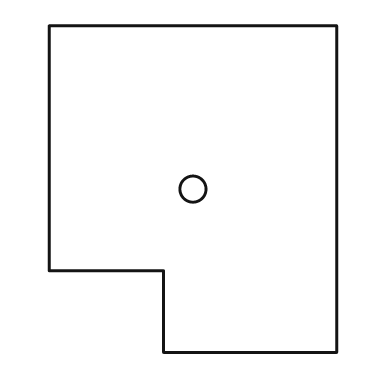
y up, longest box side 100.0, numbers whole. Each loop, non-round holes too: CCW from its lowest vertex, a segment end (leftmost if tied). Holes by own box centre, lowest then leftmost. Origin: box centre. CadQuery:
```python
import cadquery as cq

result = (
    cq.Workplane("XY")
    .moveTo(-9.0, -50.0)
    .lineTo(44.0, -50.0)
    .lineTo(44.0, 50.0)
    .lineTo(-44.0, 50.0)
    .lineTo(-44.0, -25.0)
    .lineTo(-9.0, -25.0)
    .close()
    .moveTo(0.0, 0.0)
    .circle(4.0)
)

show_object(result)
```